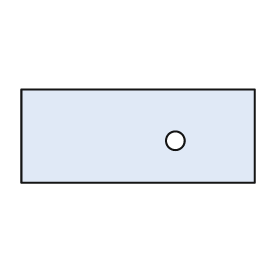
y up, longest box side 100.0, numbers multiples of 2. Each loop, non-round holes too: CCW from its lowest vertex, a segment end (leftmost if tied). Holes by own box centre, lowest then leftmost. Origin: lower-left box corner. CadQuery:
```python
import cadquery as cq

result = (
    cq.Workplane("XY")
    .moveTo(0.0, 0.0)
    .lineTo(100.0, 0.0)
    .lineTo(100.0, 40.0)
    .lineTo(0.0, 40.0)
    .close()
    .moveTo(66.0, 18.0)
    .circle(4.0)
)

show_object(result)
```